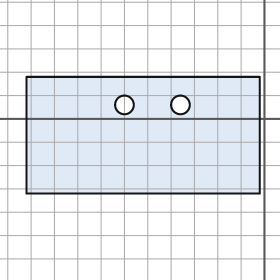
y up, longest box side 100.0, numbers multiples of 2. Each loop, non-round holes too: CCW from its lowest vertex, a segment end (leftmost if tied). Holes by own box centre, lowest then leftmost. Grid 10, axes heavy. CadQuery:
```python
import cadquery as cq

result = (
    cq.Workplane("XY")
    .moveTo(-102.0, -32.0)
    .lineTo(-2.0, -32.0)
    .lineTo(-2.0, 18.0)
    .lineTo(-102.0, 18.0)
    .close()
    .moveTo(-60.0, 6.0)
    .circle(4.0)
    .moveTo(-36.0, 6.0)
    .circle(4.0)
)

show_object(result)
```